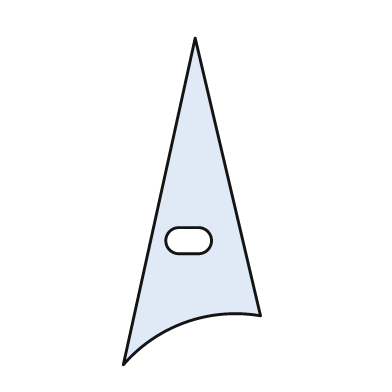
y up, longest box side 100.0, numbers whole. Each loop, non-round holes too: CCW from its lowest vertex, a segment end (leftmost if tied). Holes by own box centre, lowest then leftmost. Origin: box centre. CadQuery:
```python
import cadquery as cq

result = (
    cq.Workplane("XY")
    .moveTo(-21.0, -50.0)
    .threePointArc((-2.0, -37.0), (21.0, -35.0))
    .lineTo(1.0, 50.0)
    .close()
    .moveTo(-4.0, -16.0)
    .lineTo(2.0, -16.0)
    .threePointArc((6.0, -12.0), (2.0, -8.0))
    .lineTo(-4.0, -8.0)
    .threePointArc((-8.0, -12.0), (-4.0, -16.0))
    .close()
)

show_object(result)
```